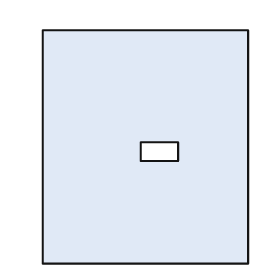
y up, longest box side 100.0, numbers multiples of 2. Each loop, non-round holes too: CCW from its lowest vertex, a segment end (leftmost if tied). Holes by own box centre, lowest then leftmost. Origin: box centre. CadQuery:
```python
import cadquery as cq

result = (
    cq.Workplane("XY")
    .moveTo(-44.0, -50.0)
    .lineTo(44.0, -50.0)
    .lineTo(44.0, 50.0)
    .lineTo(-44.0, 50.0)
    .close()
    .moveTo(-2.0, -6.0)
    .lineTo(14.0, -6.0)
    .lineTo(14.0, 2.0)
    .lineTo(-2.0, 2.0)
    .close()
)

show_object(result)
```